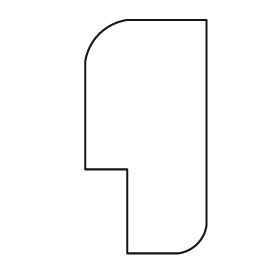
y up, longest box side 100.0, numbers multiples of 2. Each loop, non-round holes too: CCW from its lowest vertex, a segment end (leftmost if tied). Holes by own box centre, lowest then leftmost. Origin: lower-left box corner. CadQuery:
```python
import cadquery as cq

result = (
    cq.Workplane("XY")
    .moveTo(18.0, 0.0)
    .lineTo(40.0, 0.0)
    .threePointArc((48.0, 4.0), (52.0, 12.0))
    .lineTo(52.0, 100.0)
    .lineTo(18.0, 100.0)
    .threePointArc((6.0, 94.0), (0.0, 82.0))
    .lineTo(0.0, 36.0)
    .lineTo(18.0, 36.0)
    .close()
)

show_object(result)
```